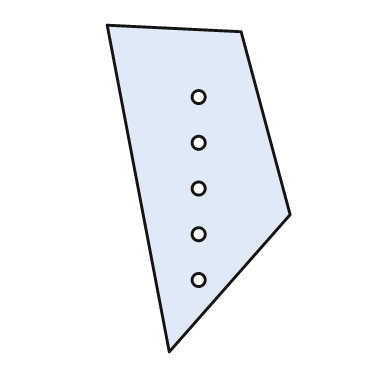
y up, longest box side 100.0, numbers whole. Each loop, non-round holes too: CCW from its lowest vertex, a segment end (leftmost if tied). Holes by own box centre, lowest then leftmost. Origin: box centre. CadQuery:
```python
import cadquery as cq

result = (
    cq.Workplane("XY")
    .moveTo(-9.0, -50.0)
    .lineTo(28.0, -8.0)
    .lineTo(13.0, 48.0)
    .lineTo(-28.0, 50.0)
    .close()
    .moveTo(0.0, -28.0)
    .circle(2.0)
    .moveTo(0.0, -14.0)
    .circle(2.0)
    .moveTo(0.0, 0.0)
    .circle(2.0)
    .moveTo(0.0, 14.0)
    .circle(2.0)
    .moveTo(0.0, 28.0)
    .circle(2.0)
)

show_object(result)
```